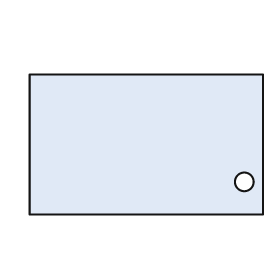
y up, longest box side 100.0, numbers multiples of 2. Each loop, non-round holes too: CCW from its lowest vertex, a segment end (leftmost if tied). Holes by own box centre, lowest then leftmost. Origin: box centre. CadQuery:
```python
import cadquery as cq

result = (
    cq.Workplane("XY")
    .moveTo(-50.0, -30.0)
    .lineTo(50.0, -30.0)
    .lineTo(50.0, 30.0)
    .lineTo(-50.0, 30.0)
    .close()
    .moveTo(42.0, -16.0)
    .circle(4.0)
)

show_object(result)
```